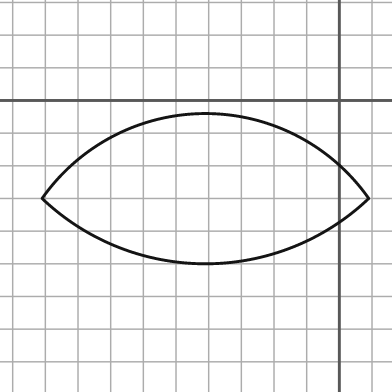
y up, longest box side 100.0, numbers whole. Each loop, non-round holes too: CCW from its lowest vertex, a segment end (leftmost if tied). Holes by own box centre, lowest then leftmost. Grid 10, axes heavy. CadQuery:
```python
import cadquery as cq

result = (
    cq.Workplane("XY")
    .moveTo(-91.0, -30.0)
    .threePointArc((-41.0, -50.0), (9.0, -30.0))
    .threePointArc((-41.0, -4.0), (-91.0, -30.0))
    .close()
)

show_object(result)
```